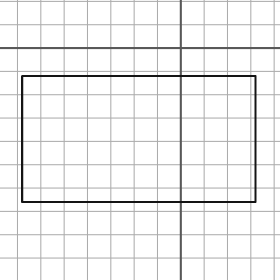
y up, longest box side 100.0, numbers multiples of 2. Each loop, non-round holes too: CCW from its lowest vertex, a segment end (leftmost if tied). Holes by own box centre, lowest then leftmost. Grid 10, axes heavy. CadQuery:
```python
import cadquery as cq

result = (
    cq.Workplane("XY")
    .moveTo(-68.0, -66.0)
    .lineTo(32.0, -66.0)
    .lineTo(32.0, -12.0)
    .lineTo(-68.0, -12.0)
    .close()
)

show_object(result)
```